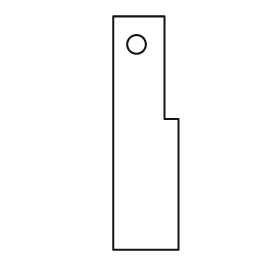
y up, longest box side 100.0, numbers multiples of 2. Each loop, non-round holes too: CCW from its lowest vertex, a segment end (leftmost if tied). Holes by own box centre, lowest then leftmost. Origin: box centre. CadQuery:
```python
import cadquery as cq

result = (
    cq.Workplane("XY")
    .moveTo(-14.0, -50.0)
    .lineTo(14.0, -50.0)
    .lineTo(14.0, 6.0)
    .lineTo(8.0, 6.0)
    .lineTo(8.0, 50.0)
    .lineTo(-14.0, 50.0)
    .close()
    .moveTo(-4.0, 38.0)
    .circle(4.0)
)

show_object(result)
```